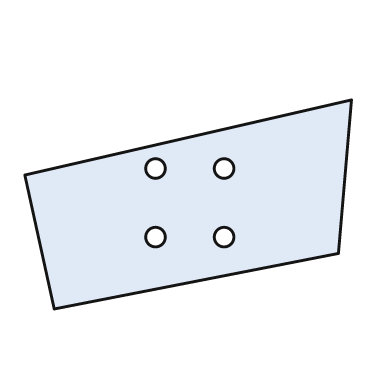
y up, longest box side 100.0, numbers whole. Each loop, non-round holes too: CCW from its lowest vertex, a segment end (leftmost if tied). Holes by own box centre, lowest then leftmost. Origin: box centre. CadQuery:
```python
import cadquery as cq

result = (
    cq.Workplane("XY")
    .moveTo(-41.0, -32.0)
    .lineTo(46.0, -15.0)
    .lineTo(50.0, 32.0)
    .lineTo(-50.0, 9.0)
    .close()
    .moveTo(-10.0, -10.0)
    .circle(3.0)
    .moveTo(11.0, -10.0)
    .circle(3.0)
    .moveTo(-10.0, 11.0)
    .circle(3.0)
    .moveTo(11.0, 11.0)
    .circle(3.0)
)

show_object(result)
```